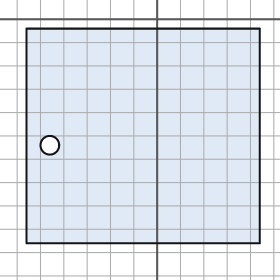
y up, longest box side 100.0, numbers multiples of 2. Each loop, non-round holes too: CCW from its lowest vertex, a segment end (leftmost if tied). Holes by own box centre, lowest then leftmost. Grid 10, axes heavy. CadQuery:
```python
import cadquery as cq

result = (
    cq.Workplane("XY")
    .moveTo(-56.0, -96.0)
    .lineTo(44.0, -96.0)
    .lineTo(44.0, -4.0)
    .lineTo(-56.0, -4.0)
    .close()
    .moveTo(-46.0, -54.0)
    .circle(4.0)
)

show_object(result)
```